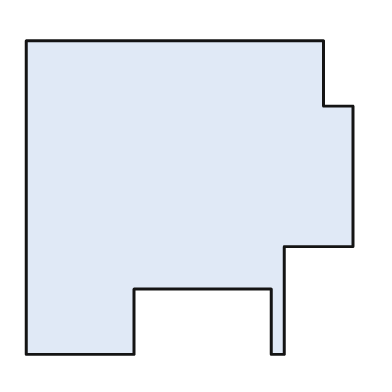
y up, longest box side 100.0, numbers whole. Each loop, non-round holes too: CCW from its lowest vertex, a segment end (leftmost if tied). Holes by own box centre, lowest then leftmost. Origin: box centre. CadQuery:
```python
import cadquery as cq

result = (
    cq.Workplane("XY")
    .moveTo(-50.0, -48.0)
    .lineTo(-17.0, -48.0)
    .lineTo(-17.0, -28.0)
    .lineTo(25.0, -28.0)
    .lineTo(25.0, -48.0)
    .lineTo(29.0, -48.0)
    .lineTo(29.0, -15.0)
    .lineTo(50.0, -15.0)
    .lineTo(50.0, 28.0)
    .lineTo(41.0, 28.0)
    .lineTo(41.0, 48.0)
    .lineTo(-50.0, 48.0)
    .close()
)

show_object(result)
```